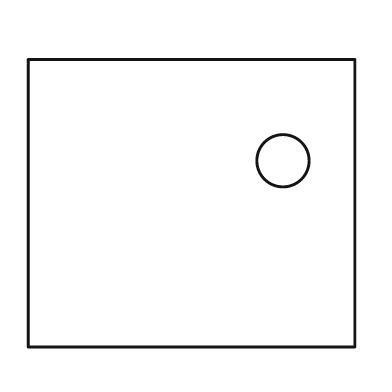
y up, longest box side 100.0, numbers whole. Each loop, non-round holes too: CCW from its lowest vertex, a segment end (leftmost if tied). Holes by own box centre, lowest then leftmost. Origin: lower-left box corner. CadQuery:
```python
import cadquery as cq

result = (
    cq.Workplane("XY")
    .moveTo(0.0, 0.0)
    .lineTo(100.0, 0.0)
    .lineTo(100.0, 88.0)
    .lineTo(0.0, 88.0)
    .close()
    .moveTo(78.0, 57.0)
    .circle(8.0)
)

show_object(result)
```